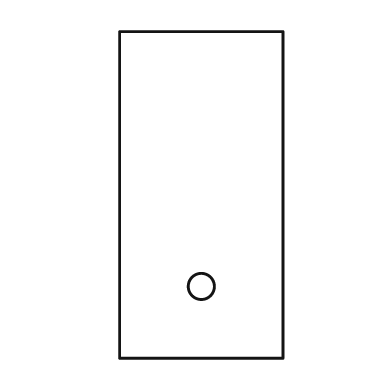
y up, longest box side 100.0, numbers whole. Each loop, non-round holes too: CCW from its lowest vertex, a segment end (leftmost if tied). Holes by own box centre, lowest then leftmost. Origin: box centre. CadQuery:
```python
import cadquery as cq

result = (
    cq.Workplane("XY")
    .moveTo(-25.0, -50.0)
    .lineTo(25.0, -50.0)
    .lineTo(25.0, 50.0)
    .lineTo(-25.0, 50.0)
    .close()
    .moveTo(0.0, -28.0)
    .circle(4.0)
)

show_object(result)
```